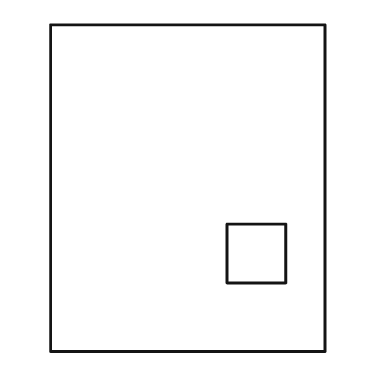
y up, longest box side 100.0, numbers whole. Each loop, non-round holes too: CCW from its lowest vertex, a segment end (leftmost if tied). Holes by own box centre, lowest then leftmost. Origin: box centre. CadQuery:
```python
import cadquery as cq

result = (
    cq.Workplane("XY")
    .moveTo(-42.0, -50.0)
    .lineTo(42.0, -50.0)
    .lineTo(42.0, 50.0)
    .lineTo(-42.0, 50.0)
    .close()
    .moveTo(12.0, -29.0)
    .lineTo(30.0, -29.0)
    .lineTo(30.0, -11.0)
    .lineTo(12.0, -11.0)
    .close()
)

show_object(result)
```